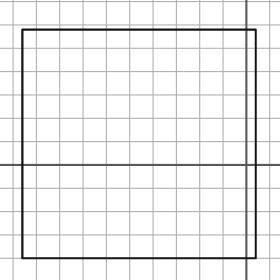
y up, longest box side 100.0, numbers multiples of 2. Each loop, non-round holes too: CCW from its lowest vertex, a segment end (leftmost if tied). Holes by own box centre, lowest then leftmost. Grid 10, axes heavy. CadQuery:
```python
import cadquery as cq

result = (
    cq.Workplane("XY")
    .moveTo(-96.0, -40.0)
    .lineTo(4.0, -40.0)
    .lineTo(4.0, 58.0)
    .lineTo(-96.0, 58.0)
    .close()
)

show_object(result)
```